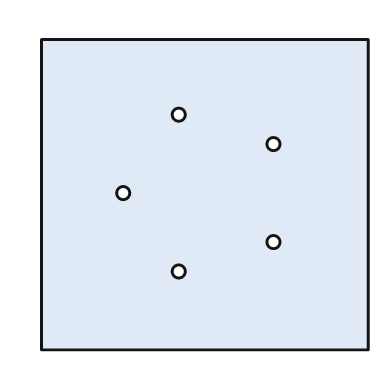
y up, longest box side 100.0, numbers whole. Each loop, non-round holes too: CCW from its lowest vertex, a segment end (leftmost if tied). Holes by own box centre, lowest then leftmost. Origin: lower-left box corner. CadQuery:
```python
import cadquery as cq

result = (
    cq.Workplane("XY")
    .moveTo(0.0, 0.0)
    .lineTo(100.0, 0.0)
    .lineTo(100.0, 95.0)
    .lineTo(0.0, 95.0)
    .close()
    .moveTo(42.0, 24.0)
    .circle(2.0)
    .moveTo(71.0, 33.0)
    .circle(2.0)
    .moveTo(25.0, 48.0)
    .circle(2.0)
    .moveTo(71.0, 63.0)
    .circle(2.0)
    .moveTo(42.0, 72.0)
    .circle(2.0)
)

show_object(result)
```